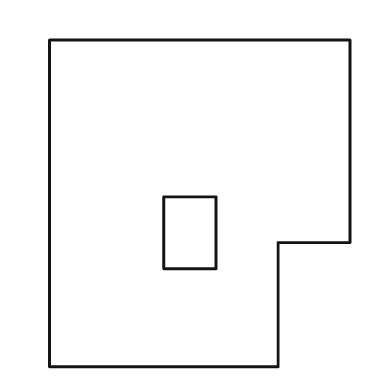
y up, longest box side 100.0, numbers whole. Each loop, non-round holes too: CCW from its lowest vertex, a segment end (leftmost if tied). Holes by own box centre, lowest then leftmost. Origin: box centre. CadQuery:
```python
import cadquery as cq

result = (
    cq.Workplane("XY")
    .moveTo(-46.0, -50.0)
    .lineTo(24.0, -50.0)
    .lineTo(24.0, -12.0)
    .lineTo(46.0, -12.0)
    .lineTo(46.0, 50.0)
    .lineTo(-46.0, 50.0)
    .close()
    .moveTo(-11.0, -20.0)
    .lineTo(5.0, -20.0)
    .lineTo(5.0, 2.0)
    .lineTo(-11.0, 2.0)
    .close()
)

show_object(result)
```